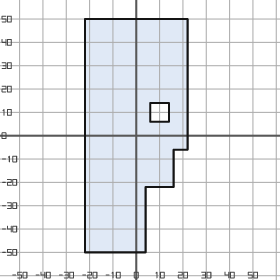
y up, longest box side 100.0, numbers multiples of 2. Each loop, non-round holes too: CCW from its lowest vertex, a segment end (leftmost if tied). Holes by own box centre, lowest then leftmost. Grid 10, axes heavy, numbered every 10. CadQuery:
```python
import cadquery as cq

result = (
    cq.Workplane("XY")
    .moveTo(-22.0, -50.0)
    .lineTo(4.0, -50.0)
    .lineTo(4.0, -22.0)
    .lineTo(16.0, -22.0)
    .lineTo(16.0, -6.0)
    .lineTo(22.0, -6.0)
    .lineTo(22.0, 50.0)
    .lineTo(-22.0, 50.0)
    .close()
    .moveTo(6.0, 6.0)
    .lineTo(14.0, 6.0)
    .lineTo(14.0, 14.0)
    .lineTo(6.0, 14.0)
    .close()
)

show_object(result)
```